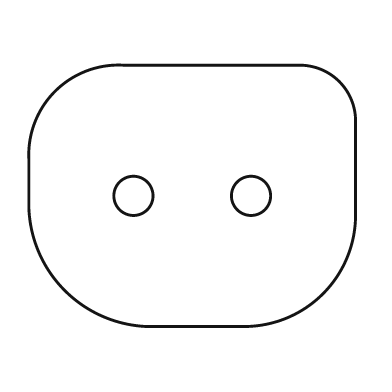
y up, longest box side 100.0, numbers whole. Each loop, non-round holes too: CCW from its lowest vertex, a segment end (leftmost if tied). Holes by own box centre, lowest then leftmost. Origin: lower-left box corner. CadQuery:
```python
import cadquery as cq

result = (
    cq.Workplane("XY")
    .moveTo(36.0, 0.0)
    .lineTo(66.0, 0.0)
    .threePointArc((90.0, 10.0), (100.0, 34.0))
    .lineTo(100.0, 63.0)
    .threePointArc((95.0, 75.0), (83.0, 80.0))
    .lineTo(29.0, 80.0)
    .threePointArc((8.0, 72.0), (0.0, 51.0))
    .lineTo(0.0, 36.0)
    .threePointArc((11.0, 11.0), (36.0, 0.0))
    .close()
    .moveTo(32.0, 40.0)
    .circle(6.0)
    .moveTo(68.0, 40.0)
    .circle(6.0)
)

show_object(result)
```